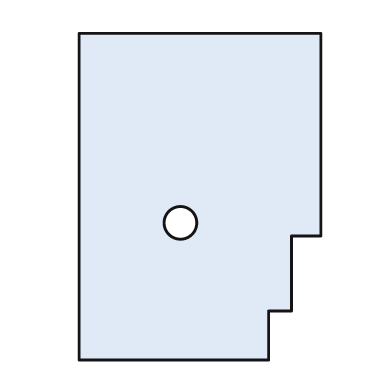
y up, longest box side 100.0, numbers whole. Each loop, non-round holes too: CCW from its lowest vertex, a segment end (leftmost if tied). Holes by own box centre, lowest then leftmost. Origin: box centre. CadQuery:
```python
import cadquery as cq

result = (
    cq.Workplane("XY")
    .moveTo(-37.0, -50.0)
    .lineTo(21.0, -50.0)
    .lineTo(21.0, -35.0)
    .lineTo(28.0, -35.0)
    .lineTo(28.0, -12.0)
    .lineTo(37.0, -12.0)
    .lineTo(37.0, 50.0)
    .lineTo(-37.0, 50.0)
    .close()
    .moveTo(-6.0, -8.0)
    .circle(5.0)
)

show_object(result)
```